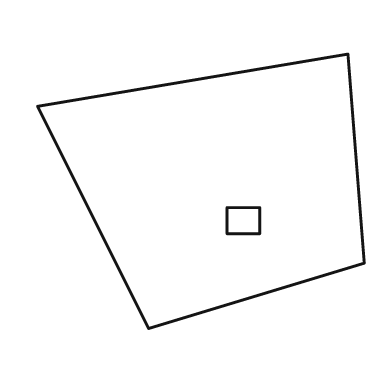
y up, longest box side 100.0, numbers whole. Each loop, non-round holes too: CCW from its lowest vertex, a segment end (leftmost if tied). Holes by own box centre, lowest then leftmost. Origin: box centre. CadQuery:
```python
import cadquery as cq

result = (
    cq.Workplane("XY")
    .moveTo(-16.0, -42.0)
    .lineTo(50.0, -22.0)
    .lineTo(45.0, 42.0)
    .lineTo(-50.0, 26.0)
    .close()
    .moveTo(8.0, -13.0)
    .lineTo(18.0, -13.0)
    .lineTo(18.0, -5.0)
    .lineTo(8.0, -5.0)
    .close()
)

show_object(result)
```